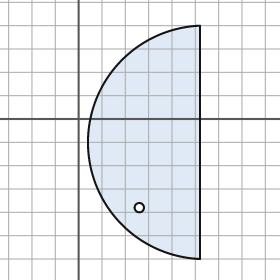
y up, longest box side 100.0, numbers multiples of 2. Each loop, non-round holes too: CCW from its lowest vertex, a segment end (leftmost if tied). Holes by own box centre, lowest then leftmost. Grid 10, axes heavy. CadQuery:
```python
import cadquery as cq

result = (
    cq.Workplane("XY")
    .moveTo(52.0, -60.0)
    .lineTo(52.0, 40.0)
    .threePointArc((4.0, -10.0), (52.0, -60.0))
    .close()
    .moveTo(26.0, -38.0)
    .circle(2.0)
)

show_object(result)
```